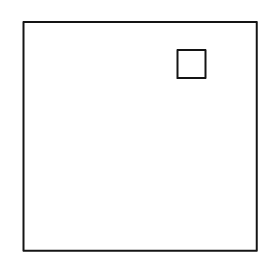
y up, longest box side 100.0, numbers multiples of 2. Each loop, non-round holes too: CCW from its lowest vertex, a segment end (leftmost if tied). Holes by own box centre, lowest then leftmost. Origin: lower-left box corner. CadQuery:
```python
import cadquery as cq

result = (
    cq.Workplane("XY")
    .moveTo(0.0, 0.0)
    .lineTo(100.0, 0.0)
    .lineTo(100.0, 98.0)
    .lineTo(0.0, 98.0)
    .close()
    .moveTo(66.0, 74.0)
    .lineTo(78.0, 74.0)
    .lineTo(78.0, 86.0)
    .lineTo(66.0, 86.0)
    .close()
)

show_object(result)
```